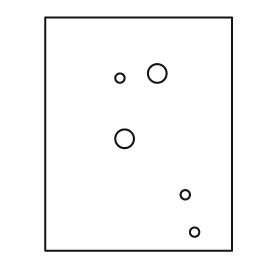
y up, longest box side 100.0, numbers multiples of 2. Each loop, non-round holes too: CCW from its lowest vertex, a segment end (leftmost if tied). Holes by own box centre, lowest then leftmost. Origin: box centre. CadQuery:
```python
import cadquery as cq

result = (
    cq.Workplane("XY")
    .moveTo(-40.0, -50.0)
    .lineTo(40.0, -50.0)
    .lineTo(40.0, 50.0)
    .lineTo(-40.0, 50.0)
    .close()
    .moveTo(24.0, -42.0)
    .circle(2.0)
    .moveTo(20.0, -26.0)
    .circle(2.0)
    .moveTo(-6.0, -2.0)
    .circle(4.0)
    .moveTo(-8.0, 24.0)
    .circle(2.0)
    .moveTo(8.0, 26.0)
    .circle(4.0)
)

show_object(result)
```